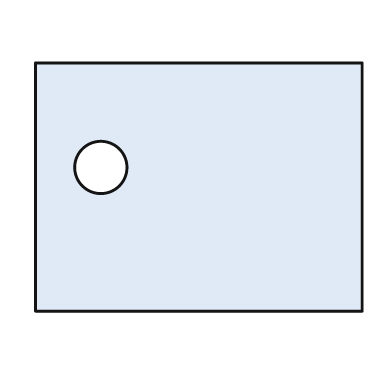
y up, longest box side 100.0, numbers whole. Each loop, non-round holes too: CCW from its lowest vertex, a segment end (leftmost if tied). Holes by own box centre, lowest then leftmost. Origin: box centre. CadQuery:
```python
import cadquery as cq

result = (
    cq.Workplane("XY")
    .moveTo(-50.0, -38.0)
    .lineTo(50.0, -38.0)
    .lineTo(50.0, 38.0)
    .lineTo(-50.0, 38.0)
    .close()
    .moveTo(-30.0, 6.0)
    .circle(8.0)
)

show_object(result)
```